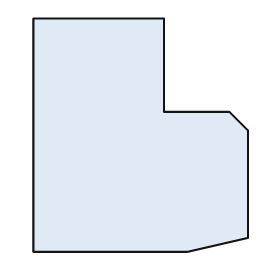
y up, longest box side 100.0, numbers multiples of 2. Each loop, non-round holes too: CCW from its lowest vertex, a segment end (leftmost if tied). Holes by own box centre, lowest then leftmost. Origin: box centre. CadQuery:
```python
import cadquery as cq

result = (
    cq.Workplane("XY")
    .moveTo(-46.0, -50.0)
    .lineTo(20.0, -50.0)
    .lineTo(46.0, -44.0)
    .lineTo(46.0, 2.0)
    .lineTo(38.0, 10.0)
    .lineTo(10.0, 10.0)
    .lineTo(10.0, 50.0)
    .lineTo(-46.0, 50.0)
    .close()
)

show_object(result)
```